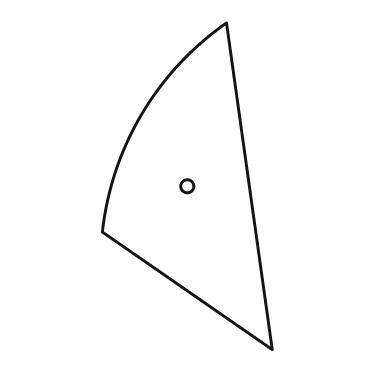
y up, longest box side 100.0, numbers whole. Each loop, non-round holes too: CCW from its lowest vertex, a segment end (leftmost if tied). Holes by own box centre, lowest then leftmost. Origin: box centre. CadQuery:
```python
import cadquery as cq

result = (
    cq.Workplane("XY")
    .moveTo(26.0, -50.0)
    .lineTo(12.0, 50.0)
    .threePointArc((-14.0, 22.0), (-26.0, -14.0))
    .close()
    .moveTo(0.0, 0.0)
    .circle(2.0)
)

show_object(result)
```